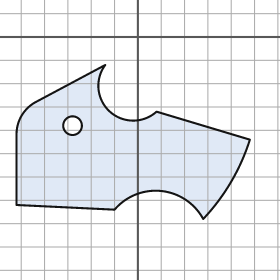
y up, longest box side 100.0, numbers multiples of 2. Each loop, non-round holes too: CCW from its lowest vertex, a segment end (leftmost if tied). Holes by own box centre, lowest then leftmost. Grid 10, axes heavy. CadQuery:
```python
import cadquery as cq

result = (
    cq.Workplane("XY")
    .moveTo(28.0, -78.0)
    .threePointArc((40.0, -62.0), (48.0, -44.0))
    .lineTo(8.0, -32.0)
    .threePointArc((-12.0, -32.0), (-14.0, -12.0))
    .lineTo(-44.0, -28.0)
    .threePointArc((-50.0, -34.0), (-52.0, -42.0))
    .lineTo(-52.0, -72.0)
    .lineTo(-10.0, -74.0)
    .threePointArc((10.0, -66.0), (28.0, -78.0))
    .close()
    .moveTo(-28.0, -38.0)
    .circle(4.0)
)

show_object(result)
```